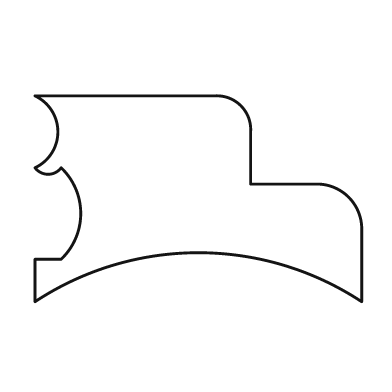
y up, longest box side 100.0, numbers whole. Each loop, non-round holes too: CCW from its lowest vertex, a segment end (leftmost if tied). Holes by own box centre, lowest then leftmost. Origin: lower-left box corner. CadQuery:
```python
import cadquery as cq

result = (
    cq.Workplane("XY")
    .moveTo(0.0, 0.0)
    .threePointArc((50.0, 15.0), (100.0, 0.0))
    .lineTo(100.0, 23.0)
    .threePointArc((96.0, 32.0), (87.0, 36.0))
    .lineTo(66.0, 36.0)
    .lineTo(66.0, 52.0)
    .threePointArc((63.0, 60.0), (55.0, 63.0))
    .lineTo(0.0, 63.0)
    .threePointArc((7.0, 52.0), (0.0, 41.0))
    .threePointArc((4.0, 39.0), (8.0, 41.0))
    .threePointArc((14.0, 27.0), (8.0, 13.0))
    .lineTo(0.0, 13.0)
    .close()
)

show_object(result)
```